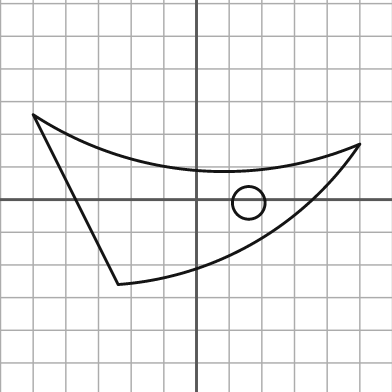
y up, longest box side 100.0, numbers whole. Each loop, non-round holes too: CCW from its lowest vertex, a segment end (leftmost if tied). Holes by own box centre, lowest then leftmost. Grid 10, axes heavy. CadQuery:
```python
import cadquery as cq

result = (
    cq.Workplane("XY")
    .moveTo(-24.0, -26.0)
    .threePointArc((18.0, -13.0), (50.0, 17.0))
    .threePointArc((-1.0, 9.0), (-50.0, 26.0))
    .close()
    .moveTo(16.0, -1.0)
    .circle(5.0)
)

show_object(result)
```